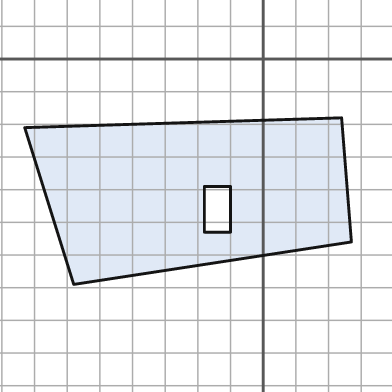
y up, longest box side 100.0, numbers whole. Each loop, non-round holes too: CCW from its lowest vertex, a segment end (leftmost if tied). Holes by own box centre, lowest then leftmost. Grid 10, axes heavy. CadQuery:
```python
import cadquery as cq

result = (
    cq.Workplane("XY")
    .moveTo(-58.0, -69.0)
    .lineTo(27.0, -56.0)
    .lineTo(24.0, -18.0)
    .lineTo(-73.0, -21.0)
    .close()
    .moveTo(-18.0, -53.0)
    .lineTo(-10.0, -53.0)
    .lineTo(-10.0, -39.0)
    .lineTo(-18.0, -39.0)
    .close()
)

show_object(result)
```